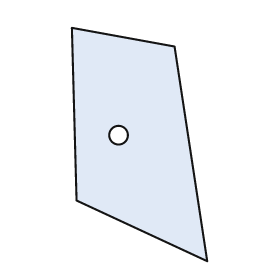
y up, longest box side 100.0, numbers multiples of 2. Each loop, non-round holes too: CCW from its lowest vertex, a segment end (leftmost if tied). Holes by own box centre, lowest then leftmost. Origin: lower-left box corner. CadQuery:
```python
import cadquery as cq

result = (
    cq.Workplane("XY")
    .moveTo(58.0, 0.0)
    .lineTo(44.0, 92.0)
    .lineTo(0.0, 100.0)
    .lineTo(2.0, 26.0)
    .close()
    .moveTo(20.0, 54.0)
    .circle(4.0)
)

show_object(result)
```